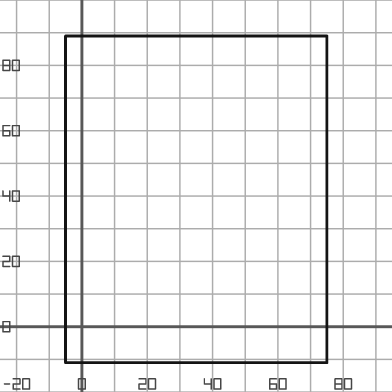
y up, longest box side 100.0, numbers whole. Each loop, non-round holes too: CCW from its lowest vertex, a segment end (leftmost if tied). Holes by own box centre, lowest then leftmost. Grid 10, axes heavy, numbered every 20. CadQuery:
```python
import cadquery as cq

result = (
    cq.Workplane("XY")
    .moveTo(-5.0, -11.0)
    .lineTo(75.0, -11.0)
    .lineTo(75.0, 89.0)
    .lineTo(-5.0, 89.0)
    .close()
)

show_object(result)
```